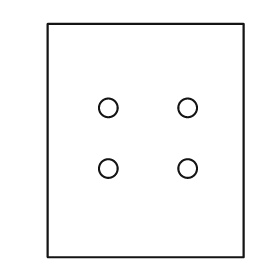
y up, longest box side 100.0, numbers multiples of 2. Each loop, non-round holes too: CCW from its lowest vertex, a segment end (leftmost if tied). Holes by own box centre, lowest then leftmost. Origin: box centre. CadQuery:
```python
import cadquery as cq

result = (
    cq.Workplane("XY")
    .moveTo(-42.0, -50.0)
    .lineTo(42.0, -50.0)
    .lineTo(42.0, 50.0)
    .lineTo(-42.0, 50.0)
    .close()
    .moveTo(-16.0, -12.0)
    .circle(4.0)
    .moveTo(18.0, -12.0)
    .circle(4.0)
    .moveTo(-16.0, 14.0)
    .circle(4.0)
    .moveTo(18.0, 14.0)
    .circle(4.0)
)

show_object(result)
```